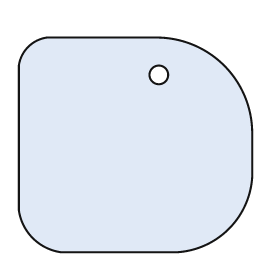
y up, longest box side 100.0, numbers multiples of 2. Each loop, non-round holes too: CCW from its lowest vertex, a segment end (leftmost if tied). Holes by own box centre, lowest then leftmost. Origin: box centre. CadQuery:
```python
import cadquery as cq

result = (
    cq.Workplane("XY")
    .moveTo(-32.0, -46.0)
    .lineTo(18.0, -46.0)
    .threePointArc((40.0, -36.0), (50.0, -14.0))
    .lineTo(50.0, 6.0)
    .threePointArc((38.0, 34.0), (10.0, 46.0))
    .lineTo(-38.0, 46.0)
    .threePointArc((-46.0, 42.0), (-50.0, 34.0))
    .lineTo(-50.0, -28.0)
    .threePointArc((-44.0, -40.0), (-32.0, -46.0))
    .close()
    .moveTo(10.0, 30.0)
    .circle(4.0)
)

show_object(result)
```